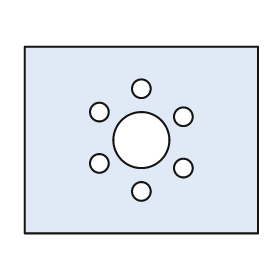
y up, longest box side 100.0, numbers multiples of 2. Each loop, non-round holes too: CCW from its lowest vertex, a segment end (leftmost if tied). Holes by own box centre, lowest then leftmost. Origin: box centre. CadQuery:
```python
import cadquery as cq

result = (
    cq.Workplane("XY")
    .moveTo(-50.0, -40.0)
    .lineTo(50.0, -40.0)
    .lineTo(50.0, 40.0)
    .lineTo(-50.0, 40.0)
    .close()
    .moveTo(0.0, -22.0)
    .circle(4.0)
    .moveTo(18.0, -12.0)
    .circle(4.0)
    .moveTo(-18.0, -10.0)
    .circle(4.0)
    .moveTo(0.0, 0.0)
    .circle(12.0)
    .moveTo(18.0, 10.0)
    .circle(4.0)
    .moveTo(-18.0, 12.0)
    .circle(4.0)
    .moveTo(0.0, 22.0)
    .circle(4.0)
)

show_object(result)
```